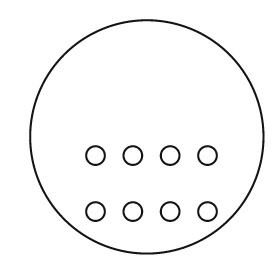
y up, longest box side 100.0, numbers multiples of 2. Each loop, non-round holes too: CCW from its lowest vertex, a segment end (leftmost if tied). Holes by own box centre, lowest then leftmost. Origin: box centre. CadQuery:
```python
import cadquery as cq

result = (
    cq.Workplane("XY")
    .moveTo(0.0, 0.0)
    .circle(50.0)
    .moveTo(-22.0, -32.0)
    .circle(4.0)
    .moveTo(-6.0, -32.0)
    .circle(4.0)
    .moveTo(10.0, -32.0)
    .circle(4.0)
    .moveTo(26.0, -32.0)
    .circle(4.0)
    .moveTo(-22.0, -8.0)
    .circle(4.0)
    .moveTo(-6.0, -8.0)
    .circle(4.0)
    .moveTo(10.0, -8.0)
    .circle(4.0)
    .moveTo(26.0, -8.0)
    .circle(4.0)
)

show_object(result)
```